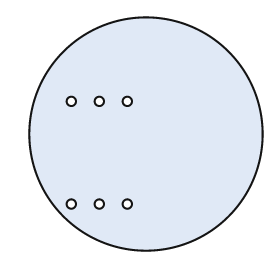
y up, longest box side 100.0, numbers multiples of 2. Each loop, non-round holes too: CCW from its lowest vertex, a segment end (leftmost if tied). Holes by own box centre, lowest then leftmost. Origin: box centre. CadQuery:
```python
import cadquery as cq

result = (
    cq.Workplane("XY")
    .moveTo(0.0, 0.0)
    .circle(50.0)
    .moveTo(-32.0, -30.0)
    .circle(2.0)
    .moveTo(-20.0, -30.0)
    .circle(2.0)
    .moveTo(-8.0, -30.0)
    .circle(2.0)
    .moveTo(-32.0, 14.0)
    .circle(2.0)
    .moveTo(-20.0, 14.0)
    .circle(2.0)
    .moveTo(-8.0, 14.0)
    .circle(2.0)
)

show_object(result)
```